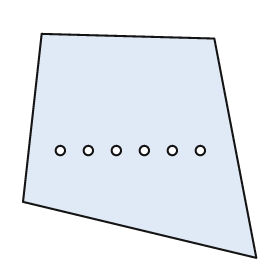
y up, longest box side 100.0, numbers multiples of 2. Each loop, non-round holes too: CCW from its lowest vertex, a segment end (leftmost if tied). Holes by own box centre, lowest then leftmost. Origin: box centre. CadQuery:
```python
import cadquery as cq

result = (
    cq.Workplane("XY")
    .moveTo(50.0, -48.0)
    .lineTo(32.0, 46.0)
    .lineTo(-42.0, 48.0)
    .lineTo(-50.0, -24.0)
    .close()
    .moveTo(-34.0, -2.0)
    .circle(2.0)
    .moveTo(-22.0, -2.0)
    .circle(2.0)
    .moveTo(-10.0, -2.0)
    .circle(2.0)
    .moveTo(2.0, -2.0)
    .circle(2.0)
    .moveTo(14.0, -2.0)
    .circle(2.0)
    .moveTo(26.0, -2.0)
    .circle(2.0)
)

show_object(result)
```